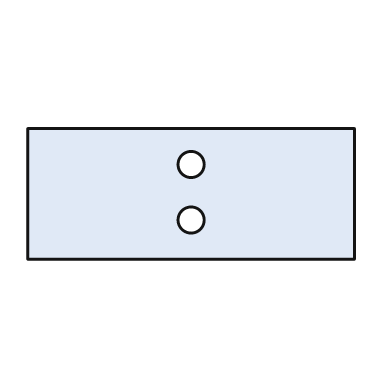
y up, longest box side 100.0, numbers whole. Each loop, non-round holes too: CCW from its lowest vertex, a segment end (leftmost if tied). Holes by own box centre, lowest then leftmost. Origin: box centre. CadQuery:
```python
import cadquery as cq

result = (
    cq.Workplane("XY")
    .moveTo(-50.0, -20.0)
    .lineTo(50.0, -20.0)
    .lineTo(50.0, 20.0)
    .lineTo(-50.0, 20.0)
    .close()
    .moveTo(0.0, -8.0)
    .circle(4.0)
    .moveTo(0.0, 9.0)
    .circle(4.0)
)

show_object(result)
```